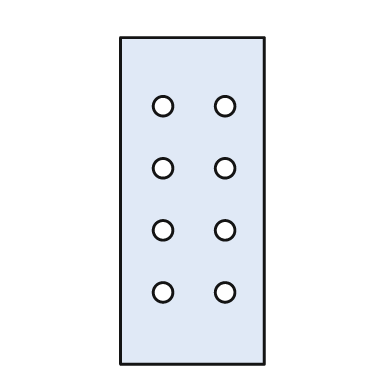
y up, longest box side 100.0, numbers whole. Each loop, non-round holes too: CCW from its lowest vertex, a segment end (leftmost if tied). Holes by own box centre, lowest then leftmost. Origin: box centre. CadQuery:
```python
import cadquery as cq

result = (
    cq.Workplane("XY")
    .moveTo(-22.0, -50.0)
    .lineTo(22.0, -50.0)
    .lineTo(22.0, 50.0)
    .lineTo(-22.0, 50.0)
    .close()
    .moveTo(-9.0, -28.0)
    .circle(3.0)
    .moveTo(10.0, -28.0)
    .circle(3.0)
    .moveTo(-9.0, -9.0)
    .circle(3.0)
    .moveTo(10.0, -9.0)
    .circle(3.0)
    .moveTo(-9.0, 10.0)
    .circle(3.0)
    .moveTo(10.0, 10.0)
    .circle(3.0)
    .moveTo(-9.0, 29.0)
    .circle(3.0)
    .moveTo(10.0, 29.0)
    .circle(3.0)
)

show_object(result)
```